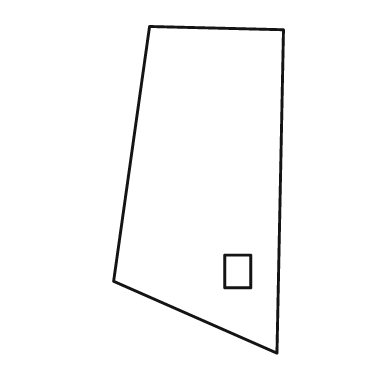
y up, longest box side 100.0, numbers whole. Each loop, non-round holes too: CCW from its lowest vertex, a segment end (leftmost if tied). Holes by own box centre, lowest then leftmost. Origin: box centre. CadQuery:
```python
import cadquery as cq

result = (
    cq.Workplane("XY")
    .moveTo(24.0, -50.0)
    .lineTo(26.0, 49.0)
    .lineTo(-15.0, 50.0)
    .lineTo(-26.0, -28.0)
    .close()
    .moveTo(8.0, -30.0)
    .lineTo(16.0, -30.0)
    .lineTo(16.0, -20.0)
    .lineTo(8.0, -20.0)
    .close()
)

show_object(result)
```